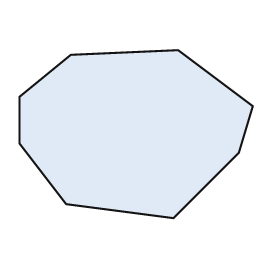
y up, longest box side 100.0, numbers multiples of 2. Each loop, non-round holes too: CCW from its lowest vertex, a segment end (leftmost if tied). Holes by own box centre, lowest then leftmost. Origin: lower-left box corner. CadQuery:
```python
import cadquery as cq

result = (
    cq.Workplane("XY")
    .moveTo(66.0, 0.0)
    .lineTo(94.0, 28.0)
    .lineTo(100.0, 48.0)
    .lineTo(68.0, 72.0)
    .lineTo(22.0, 70.0)
    .lineTo(0.0, 52.0)
    .lineTo(0.0, 32.0)
    .lineTo(20.0, 6.0)
    .close()
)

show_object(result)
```